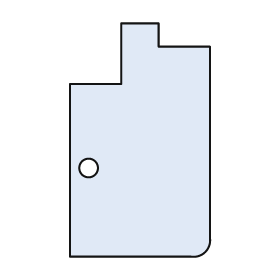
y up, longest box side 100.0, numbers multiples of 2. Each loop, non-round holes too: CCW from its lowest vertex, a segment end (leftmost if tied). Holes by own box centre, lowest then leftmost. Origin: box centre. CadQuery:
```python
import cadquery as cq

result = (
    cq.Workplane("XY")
    .moveTo(-30.0, -50.0)
    .lineTo(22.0, -50.0)
    .threePointArc((28.0, -48.0), (30.0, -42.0))
    .lineTo(30.0, 40.0)
    .lineTo(8.0, 40.0)
    .lineTo(8.0, 50.0)
    .lineTo(-8.0, 50.0)
    .lineTo(-8.0, 24.0)
    .lineTo(-30.0, 24.0)
    .close()
    .moveTo(-22.0, -12.0)
    .circle(4.0)
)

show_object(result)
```